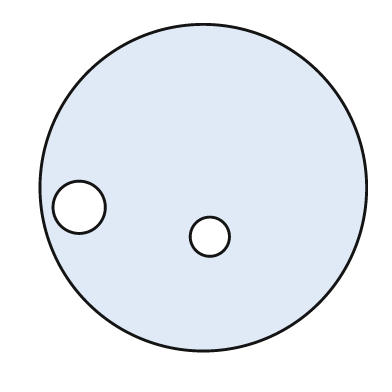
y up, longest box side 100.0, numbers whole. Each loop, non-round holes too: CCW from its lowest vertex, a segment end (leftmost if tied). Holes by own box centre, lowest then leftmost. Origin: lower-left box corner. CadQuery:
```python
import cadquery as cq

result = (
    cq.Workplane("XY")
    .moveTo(50.0, 50.0)
    .circle(50.0)
    .moveTo(52.0, 35.0)
    .circle(6.0)
    .moveTo(12.0, 44.0)
    .circle(8.0)
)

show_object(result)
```